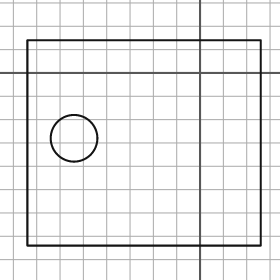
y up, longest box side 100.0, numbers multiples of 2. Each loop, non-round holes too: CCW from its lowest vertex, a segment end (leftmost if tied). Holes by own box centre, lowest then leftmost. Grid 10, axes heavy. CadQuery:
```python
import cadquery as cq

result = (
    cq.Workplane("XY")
    .moveTo(-74.0, -74.0)
    .lineTo(26.0, -74.0)
    .lineTo(26.0, 14.0)
    .lineTo(-74.0, 14.0)
    .close()
    .moveTo(-54.0, -28.0)
    .circle(10.0)
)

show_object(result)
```